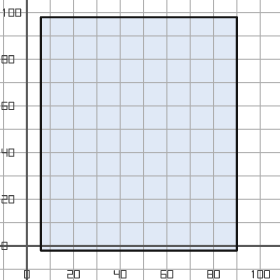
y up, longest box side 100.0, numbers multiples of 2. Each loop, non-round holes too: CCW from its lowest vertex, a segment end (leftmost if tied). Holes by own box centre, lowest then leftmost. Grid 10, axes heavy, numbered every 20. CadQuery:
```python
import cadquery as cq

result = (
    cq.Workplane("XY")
    .moveTo(6.0, -2.0)
    .lineTo(90.0, -2.0)
    .lineTo(90.0, 98.0)
    .lineTo(6.0, 98.0)
    .close()
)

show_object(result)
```